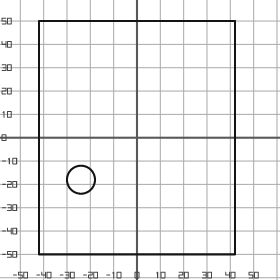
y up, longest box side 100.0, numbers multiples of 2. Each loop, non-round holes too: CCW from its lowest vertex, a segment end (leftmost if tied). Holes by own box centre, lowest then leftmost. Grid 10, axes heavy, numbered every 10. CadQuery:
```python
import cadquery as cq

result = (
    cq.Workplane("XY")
    .moveTo(-42.0, -50.0)
    .lineTo(42.0, -50.0)
    .lineTo(42.0, 50.0)
    .lineTo(-42.0, 50.0)
    .close()
    .moveTo(-24.0, -18.0)
    .circle(6.0)
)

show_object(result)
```